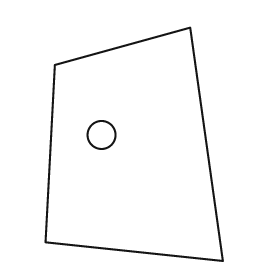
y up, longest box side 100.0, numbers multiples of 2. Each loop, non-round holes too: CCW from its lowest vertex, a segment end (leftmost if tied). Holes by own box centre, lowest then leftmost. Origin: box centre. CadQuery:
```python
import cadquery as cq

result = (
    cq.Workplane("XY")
    .moveTo(38.0, -50.0)
    .lineTo(24.0, 50.0)
    .lineTo(-34.0, 34.0)
    .lineTo(-38.0, -42.0)
    .close()
    .moveTo(-14.0, 4.0)
    .circle(6.0)
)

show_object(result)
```